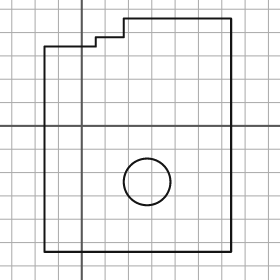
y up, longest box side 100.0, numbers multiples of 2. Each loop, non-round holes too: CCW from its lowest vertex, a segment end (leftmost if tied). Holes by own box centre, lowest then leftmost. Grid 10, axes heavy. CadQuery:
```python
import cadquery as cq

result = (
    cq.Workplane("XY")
    .moveTo(-16.0, -54.0)
    .lineTo(64.0, -54.0)
    .lineTo(64.0, 46.0)
    .lineTo(18.0, 46.0)
    .lineTo(18.0, 38.0)
    .lineTo(6.0, 38.0)
    .lineTo(6.0, 34.0)
    .lineTo(-16.0, 34.0)
    .close()
    .moveTo(28.0, -24.0)
    .circle(10.0)
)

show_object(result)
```